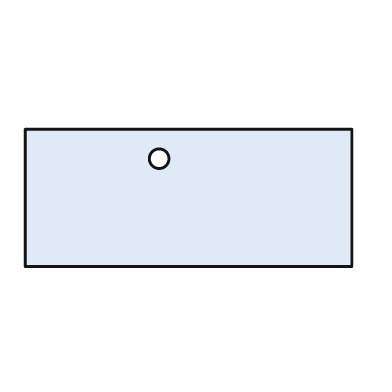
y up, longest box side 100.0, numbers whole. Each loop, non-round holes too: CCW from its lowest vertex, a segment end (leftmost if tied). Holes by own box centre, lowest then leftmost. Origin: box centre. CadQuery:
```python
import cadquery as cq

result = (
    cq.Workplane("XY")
    .moveTo(-50.0, -21.0)
    .lineTo(50.0, -21.0)
    .lineTo(50.0, 21.0)
    .lineTo(-50.0, 21.0)
    .close()
    .moveTo(-9.0, 12.0)
    .circle(3.0)
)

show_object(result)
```